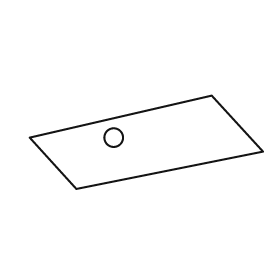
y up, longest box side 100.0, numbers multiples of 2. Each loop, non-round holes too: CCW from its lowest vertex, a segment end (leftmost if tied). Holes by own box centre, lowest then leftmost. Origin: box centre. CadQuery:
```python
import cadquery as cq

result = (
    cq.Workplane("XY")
    .moveTo(-30.0, -20.0)
    .lineTo(50.0, -4.0)
    .lineTo(28.0, 20.0)
    .lineTo(-50.0, 2.0)
    .close()
    .moveTo(-14.0, 2.0)
    .circle(4.0)
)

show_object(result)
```